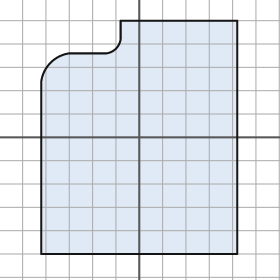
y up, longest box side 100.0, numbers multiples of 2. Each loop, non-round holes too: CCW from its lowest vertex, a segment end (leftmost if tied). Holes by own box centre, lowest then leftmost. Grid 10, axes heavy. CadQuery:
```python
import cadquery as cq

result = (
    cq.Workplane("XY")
    .moveTo(-42.0, -50.0)
    .lineTo(42.0, -50.0)
    .lineTo(42.0, 50.0)
    .lineTo(-8.0, 50.0)
    .lineTo(-8.0, 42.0)
    .threePointArc((-10.0, 38.0), (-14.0, 36.0))
    .lineTo(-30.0, 36.0)
    .threePointArc((-38.0, 32.0), (-42.0, 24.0))
    .close()
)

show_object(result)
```